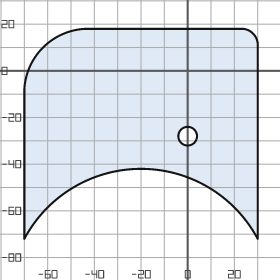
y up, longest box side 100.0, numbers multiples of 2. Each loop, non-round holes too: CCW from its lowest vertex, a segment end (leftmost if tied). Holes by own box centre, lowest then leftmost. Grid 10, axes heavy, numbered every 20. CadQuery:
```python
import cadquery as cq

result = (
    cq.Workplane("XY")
    .moveTo(-70.0, -72.0)
    .threePointArc((-20.0, -42.0), (30.0, -72.0))
    .lineTo(30.0, 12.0)
    .threePointArc((28.0, 16.0), (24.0, 18.0))
    .lineTo(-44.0, 18.0)
    .threePointArc((-62.0, 10.0), (-70.0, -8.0))
    .close()
    .moveTo(0.0, -28.0)
    .circle(4.0)
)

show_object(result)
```